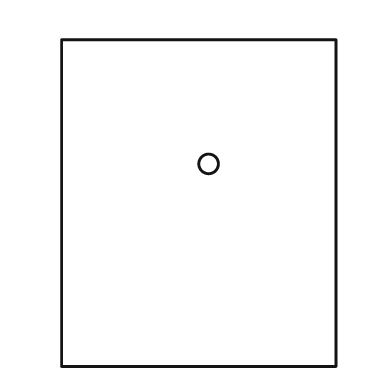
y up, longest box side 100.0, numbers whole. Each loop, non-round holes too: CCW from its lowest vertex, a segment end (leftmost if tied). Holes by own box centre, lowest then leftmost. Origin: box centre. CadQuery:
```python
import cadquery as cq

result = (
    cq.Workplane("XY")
    .moveTo(-42.0, -50.0)
    .lineTo(42.0, -50.0)
    .lineTo(42.0, 50.0)
    .lineTo(-42.0, 50.0)
    .close()
    .moveTo(3.0, 12.0)
    .circle(3.0)
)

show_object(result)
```